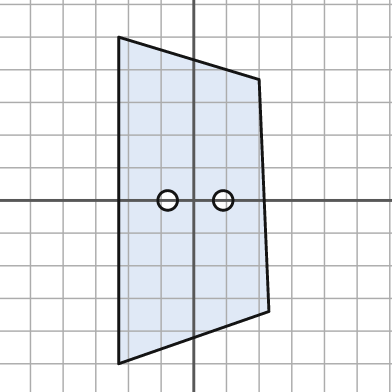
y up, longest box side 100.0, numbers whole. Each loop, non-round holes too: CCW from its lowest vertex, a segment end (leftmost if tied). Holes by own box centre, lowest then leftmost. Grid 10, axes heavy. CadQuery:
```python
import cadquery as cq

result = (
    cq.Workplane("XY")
    .moveTo(-23.0, -50.0)
    .lineTo(23.0, -34.0)
    .lineTo(20.0, 37.0)
    .lineTo(-23.0, 50.0)
    .close()
    .moveTo(-8.0, 0.0)
    .circle(3.0)
    .moveTo(9.0, 0.0)
    .circle(3.0)
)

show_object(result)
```